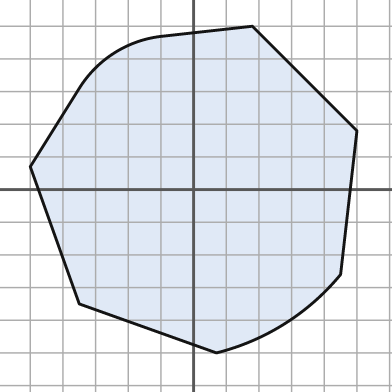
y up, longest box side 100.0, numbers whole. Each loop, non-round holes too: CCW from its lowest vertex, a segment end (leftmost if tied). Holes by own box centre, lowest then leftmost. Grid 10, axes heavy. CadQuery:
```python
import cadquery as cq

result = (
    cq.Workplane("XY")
    .moveTo(7.0, -50.0)
    .threePointArc((28.0, -41.0), (45.0, -26.0))
    .lineTo(50.0, 18.0)
    .lineTo(18.0, 50.0)
    .lineTo(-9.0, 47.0)
    .threePointArc((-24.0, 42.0), (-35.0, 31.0))
    .lineTo(-50.0, 7.0)
    .lineTo(-35.0, -35.0)
    .close()
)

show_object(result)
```